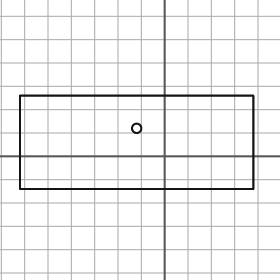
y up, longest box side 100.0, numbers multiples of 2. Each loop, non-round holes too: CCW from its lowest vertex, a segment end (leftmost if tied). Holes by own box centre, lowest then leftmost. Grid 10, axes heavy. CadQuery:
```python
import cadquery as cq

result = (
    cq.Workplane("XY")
    .moveTo(-62.0, -14.0)
    .lineTo(38.0, -14.0)
    .lineTo(38.0, 26.0)
    .lineTo(-62.0, 26.0)
    .close()
    .moveTo(-12.0, 12.0)
    .circle(2.0)
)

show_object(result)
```